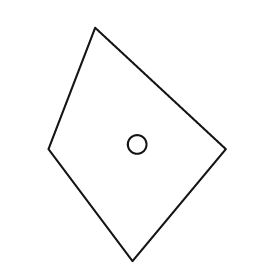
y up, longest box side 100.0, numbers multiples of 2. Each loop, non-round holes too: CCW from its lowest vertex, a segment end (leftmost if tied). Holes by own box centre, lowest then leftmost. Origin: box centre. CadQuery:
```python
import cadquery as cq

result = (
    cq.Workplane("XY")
    .moveTo(-2.0, -50.0)
    .lineTo(38.0, -2.0)
    .lineTo(-18.0, 50.0)
    .lineTo(-38.0, -2.0)
    .close()
    .moveTo(0.0, 0.0)
    .circle(4.0)
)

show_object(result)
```